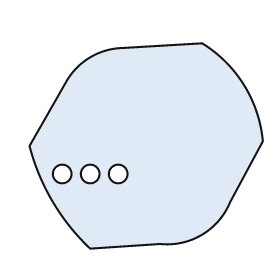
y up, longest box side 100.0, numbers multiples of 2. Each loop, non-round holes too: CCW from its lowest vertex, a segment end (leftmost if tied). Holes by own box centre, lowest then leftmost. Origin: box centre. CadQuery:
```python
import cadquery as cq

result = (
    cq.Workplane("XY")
    .moveTo(-24.0, -44.0)
    .lineTo(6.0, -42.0)
    .threePointArc((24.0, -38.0), (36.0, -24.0))
    .lineTo(50.0, 2.0)
    .threePointArc((42.0, 26.0), (24.0, 44.0))
    .lineTo(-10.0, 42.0)
    .threePointArc((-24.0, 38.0), (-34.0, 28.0))
    .lineTo(-50.0, 0.0)
    .threePointArc((-40.0, -24.0), (-24.0, -44.0))
    .close()
    .moveTo(-36.0, -12.0)
    .circle(4.0)
    .moveTo(-24.0, -12.0)
    .circle(4.0)
    .moveTo(-12.0, -12.0)
    .circle(4.0)
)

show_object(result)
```